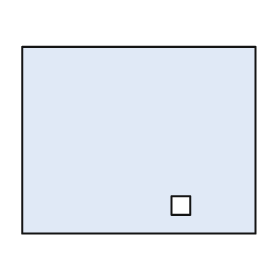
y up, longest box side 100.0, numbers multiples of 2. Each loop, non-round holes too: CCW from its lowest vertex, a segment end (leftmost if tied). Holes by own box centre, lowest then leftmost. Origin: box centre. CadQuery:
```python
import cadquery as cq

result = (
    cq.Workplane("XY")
    .moveTo(-50.0, -40.0)
    .lineTo(50.0, -40.0)
    .lineTo(50.0, 40.0)
    .lineTo(-50.0, 40.0)
    .close()
    .moveTo(14.0, -32.0)
    .lineTo(22.0, -32.0)
    .lineTo(22.0, -24.0)
    .lineTo(14.0, -24.0)
    .close()
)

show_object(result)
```